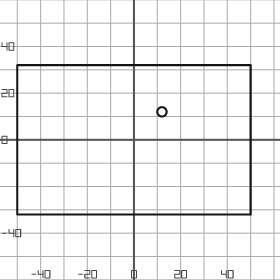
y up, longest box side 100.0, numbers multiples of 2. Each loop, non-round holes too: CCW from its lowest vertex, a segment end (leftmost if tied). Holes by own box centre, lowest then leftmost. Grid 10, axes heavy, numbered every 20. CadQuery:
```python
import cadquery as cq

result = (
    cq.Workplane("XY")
    .moveTo(-50.0, -32.0)
    .lineTo(50.0, -32.0)
    .lineTo(50.0, 32.0)
    .lineTo(-50.0, 32.0)
    .close()
    .moveTo(12.0, 12.0)
    .circle(2.0)
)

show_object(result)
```